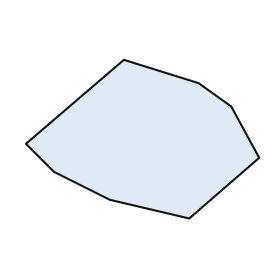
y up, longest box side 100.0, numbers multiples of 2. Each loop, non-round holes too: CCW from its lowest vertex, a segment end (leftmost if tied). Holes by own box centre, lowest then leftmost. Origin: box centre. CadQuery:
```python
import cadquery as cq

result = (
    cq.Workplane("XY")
    .moveTo(20.0, -34.0)
    .lineTo(50.0, -8.0)
    .lineTo(38.0, 14.0)
    .lineTo(24.0, 24.0)
    .lineTo(-8.0, 34.0)
    .lineTo(-50.0, -2.0)
    .lineTo(-38.0, -14.0)
    .lineTo(-14.0, -26.0)
    .close()
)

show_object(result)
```